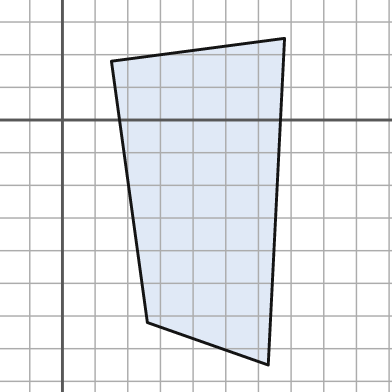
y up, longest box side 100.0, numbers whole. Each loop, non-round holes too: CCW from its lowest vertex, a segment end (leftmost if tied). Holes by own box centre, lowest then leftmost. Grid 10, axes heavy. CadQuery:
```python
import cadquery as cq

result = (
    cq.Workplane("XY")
    .moveTo(63.0, -75.0)
    .lineTo(68.0, 25.0)
    .lineTo(15.0, 18.0)
    .lineTo(26.0, -62.0)
    .close()
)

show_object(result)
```